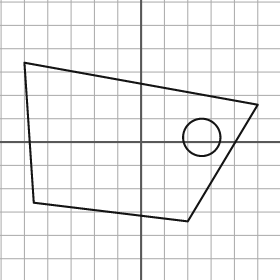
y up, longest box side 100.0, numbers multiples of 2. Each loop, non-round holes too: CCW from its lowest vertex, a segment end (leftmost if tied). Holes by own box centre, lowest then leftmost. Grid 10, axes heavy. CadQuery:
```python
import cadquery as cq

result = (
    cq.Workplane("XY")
    .moveTo(20.0, -34.0)
    .lineTo(50.0, 16.0)
    .lineTo(-50.0, 34.0)
    .lineTo(-46.0, -26.0)
    .close()
    .moveTo(26.0, 2.0)
    .circle(8.0)
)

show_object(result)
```